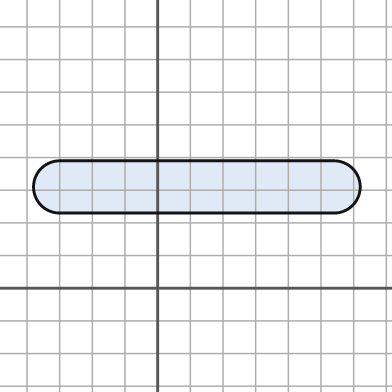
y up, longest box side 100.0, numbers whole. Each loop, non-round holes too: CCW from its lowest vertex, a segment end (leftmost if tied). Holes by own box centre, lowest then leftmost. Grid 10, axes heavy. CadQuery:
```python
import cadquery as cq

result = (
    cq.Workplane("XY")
    .moveTo(-30.0, 23.0)
    .lineTo(54.0, 23.0)
    .threePointArc((62.0, 31.0), (54.0, 39.0))
    .lineTo(-30.0, 39.0)
    .threePointArc((-38.0, 31.0), (-30.0, 23.0))
    .close()
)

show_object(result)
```